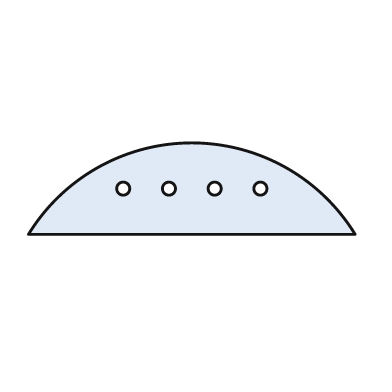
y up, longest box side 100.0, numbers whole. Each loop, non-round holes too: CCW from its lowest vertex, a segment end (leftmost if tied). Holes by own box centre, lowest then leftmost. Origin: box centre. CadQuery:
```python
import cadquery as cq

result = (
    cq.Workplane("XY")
    .moveTo(-50.0, -14.0)
    .lineTo(50.0, -14.0)
    .threePointArc((0.0, 14.0), (-50.0, -14.0))
    .close()
    .moveTo(-21.0, 0.0)
    .circle(2.0)
    .moveTo(-7.0, 0.0)
    .circle(2.0)
    .moveTo(7.0, 0.0)
    .circle(2.0)
    .moveTo(21.0, 0.0)
    .circle(2.0)
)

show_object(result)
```